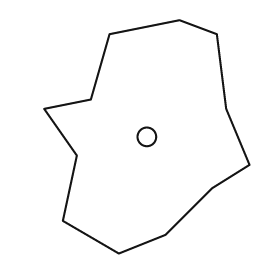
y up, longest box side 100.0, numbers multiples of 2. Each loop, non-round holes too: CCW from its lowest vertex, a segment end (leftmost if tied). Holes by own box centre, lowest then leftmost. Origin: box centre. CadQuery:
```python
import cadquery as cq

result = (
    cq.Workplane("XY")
    .moveTo(-12.0, -50.0)
    .lineTo(8.0, -42.0)
    .lineTo(28.0, -22.0)
    .lineTo(44.0, -12.0)
    .lineTo(34.0, 12.0)
    .lineTo(30.0, 44.0)
    .lineTo(14.0, 50.0)
    .lineTo(-16.0, 44.0)
    .lineTo(-24.0, 16.0)
    .lineTo(-44.0, 12.0)
    .lineTo(-30.0, -8.0)
    .lineTo(-36.0, -36.0)
    .close()
    .moveTo(0.0, 0.0)
    .circle(4.0)
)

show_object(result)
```